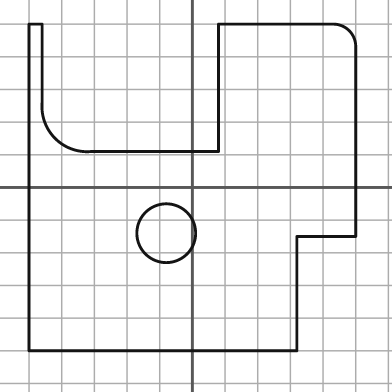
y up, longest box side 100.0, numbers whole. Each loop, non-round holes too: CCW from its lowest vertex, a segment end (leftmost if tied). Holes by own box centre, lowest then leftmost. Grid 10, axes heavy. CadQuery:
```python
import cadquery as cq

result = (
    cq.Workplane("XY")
    .moveTo(-50.0, -50.0)
    .lineTo(32.0, -50.0)
    .lineTo(32.0, -15.0)
    .lineTo(50.0, -15.0)
    .lineTo(50.0, 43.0)
    .threePointArc((48.0, 48.0), (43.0, 50.0))
    .lineTo(8.0, 50.0)
    .lineTo(8.0, 11.0)
    .lineTo(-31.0, 11.0)
    .threePointArc((-42.0, 15.0), (-46.0, 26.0))
    .lineTo(-46.0, 50.0)
    .lineTo(-50.0, 50.0)
    .close()
    .moveTo(-8.0, -14.0)
    .circle(9.0)
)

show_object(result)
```